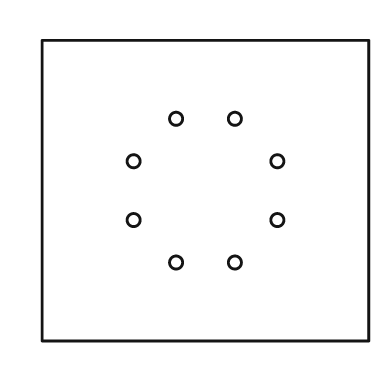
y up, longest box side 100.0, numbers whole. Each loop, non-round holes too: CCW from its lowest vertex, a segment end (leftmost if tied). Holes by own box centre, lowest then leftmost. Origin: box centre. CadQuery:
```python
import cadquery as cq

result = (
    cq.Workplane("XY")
    .moveTo(-50.0, -46.0)
    .lineTo(50.0, -46.0)
    .lineTo(50.0, 46.0)
    .lineTo(-50.0, 46.0)
    .close()
    .moveTo(-9.0, -22.0)
    .circle(2.0)
    .moveTo(9.0, -22.0)
    .circle(2.0)
    .moveTo(-22.0, -9.0)
    .circle(2.0)
    .moveTo(22.0, -9.0)
    .circle(2.0)
    .moveTo(-22.0, 9.0)
    .circle(2.0)
    .moveTo(22.0, 9.0)
    .circle(2.0)
    .moveTo(-9.0, 22.0)
    .circle(2.0)
    .moveTo(9.0, 22.0)
    .circle(2.0)
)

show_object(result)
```